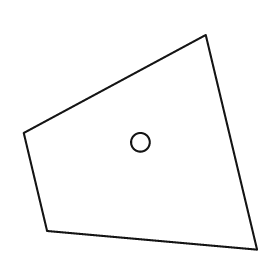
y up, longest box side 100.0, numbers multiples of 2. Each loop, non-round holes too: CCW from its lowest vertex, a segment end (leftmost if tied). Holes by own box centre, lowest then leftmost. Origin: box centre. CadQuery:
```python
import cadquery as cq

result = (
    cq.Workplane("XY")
    .moveTo(50.0, -46.0)
    .lineTo(28.0, 46.0)
    .lineTo(-50.0, 4.0)
    .lineTo(-40.0, -38.0)
    .close()
    .moveTo(0.0, 0.0)
    .circle(4.0)
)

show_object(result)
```